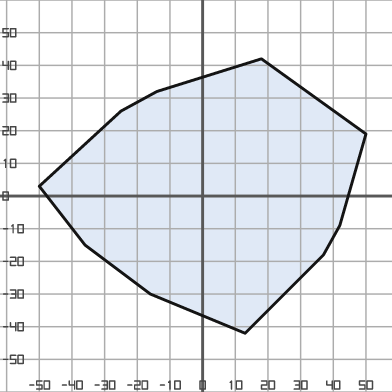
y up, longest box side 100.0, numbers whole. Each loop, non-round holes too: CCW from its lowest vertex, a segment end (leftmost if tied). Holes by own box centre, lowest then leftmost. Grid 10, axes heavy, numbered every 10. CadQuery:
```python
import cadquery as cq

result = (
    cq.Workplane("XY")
    .moveTo(13.0, -42.0)
    .lineTo(37.0, -18.0)
    .lineTo(42.0, -9.0)
    .lineTo(50.0, 19.0)
    .lineTo(18.0, 42.0)
    .lineTo(-14.0, 32.0)
    .lineTo(-25.0, 26.0)
    .lineTo(-50.0, 3.0)
    .lineTo(-36.0, -15.0)
    .lineTo(-16.0, -30.0)
    .close()
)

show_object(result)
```